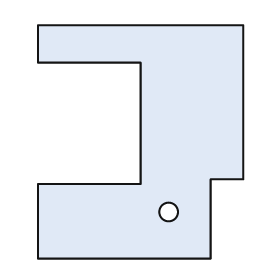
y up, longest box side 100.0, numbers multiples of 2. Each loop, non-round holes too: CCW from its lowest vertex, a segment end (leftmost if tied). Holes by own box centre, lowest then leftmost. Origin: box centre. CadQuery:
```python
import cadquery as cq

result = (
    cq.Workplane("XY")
    .moveTo(-44.0, -50.0)
    .lineTo(30.0, -50.0)
    .lineTo(30.0, -16.0)
    .lineTo(44.0, -16.0)
    .lineTo(44.0, 50.0)
    .lineTo(-44.0, 50.0)
    .lineTo(-44.0, 34.0)
    .lineTo(0.0, 34.0)
    .lineTo(0.0, -18.0)
    .lineTo(-44.0, -18.0)
    .close()
    .moveTo(12.0, -30.0)
    .circle(4.0)
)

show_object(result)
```